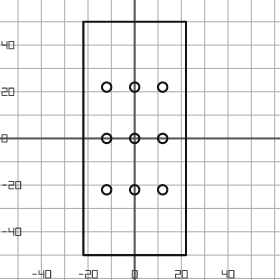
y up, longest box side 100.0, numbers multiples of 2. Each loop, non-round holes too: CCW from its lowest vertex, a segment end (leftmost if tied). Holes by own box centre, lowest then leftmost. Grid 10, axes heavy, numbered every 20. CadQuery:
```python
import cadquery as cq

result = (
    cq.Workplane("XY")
    .moveTo(-22.0, -50.0)
    .lineTo(22.0, -50.0)
    .lineTo(22.0, 50.0)
    .lineTo(-22.0, 50.0)
    .close()
    .moveTo(-12.0, -22.0)
    .circle(2.0)
    .moveTo(0.0, -22.0)
    .circle(2.0)
    .moveTo(12.0, -22.0)
    .circle(2.0)
    .moveTo(-12.0, 0.0)
    .circle(2.0)
    .moveTo(0.0, 0.0)
    .circle(2.0)
    .moveTo(12.0, 0.0)
    .circle(2.0)
    .moveTo(-12.0, 22.0)
    .circle(2.0)
    .moveTo(0.0, 22.0)
    .circle(2.0)
    .moveTo(12.0, 22.0)
    .circle(2.0)
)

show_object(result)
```